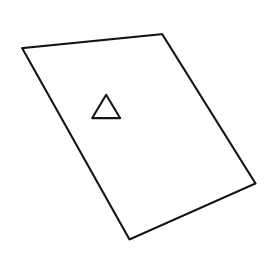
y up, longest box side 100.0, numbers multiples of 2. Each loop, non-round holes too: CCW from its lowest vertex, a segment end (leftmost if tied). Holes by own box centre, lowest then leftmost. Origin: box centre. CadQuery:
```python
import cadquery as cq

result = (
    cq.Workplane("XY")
    .moveTo(-4.0, -44.0)
    .lineTo(50.0, -20.0)
    .lineTo(10.0, 44.0)
    .lineTo(-50.0, 38.0)
    .close()
    .moveTo(-20.0, 8.0)
    .lineTo(-8.0, 8.0)
    .lineTo(-14.0, 18.0)
    .close()
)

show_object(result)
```